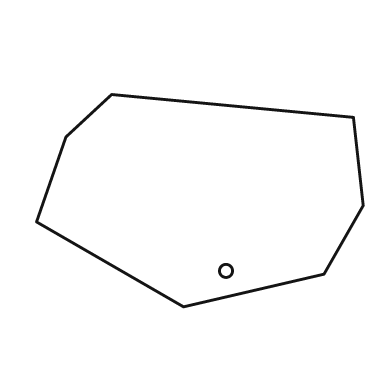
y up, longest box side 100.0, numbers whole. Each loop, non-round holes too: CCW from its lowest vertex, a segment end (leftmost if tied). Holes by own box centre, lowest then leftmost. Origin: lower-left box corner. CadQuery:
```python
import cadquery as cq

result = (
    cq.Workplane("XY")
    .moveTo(45.0, 0.0)
    .lineTo(88.0, 10.0)
    .lineTo(100.0, 31.0)
    .lineTo(97.0, 58.0)
    .lineTo(23.0, 65.0)
    .lineTo(9.0, 52.0)
    .lineTo(0.0, 26.0)
    .close()
    .moveTo(58.0, 11.0)
    .circle(2.0)
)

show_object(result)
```